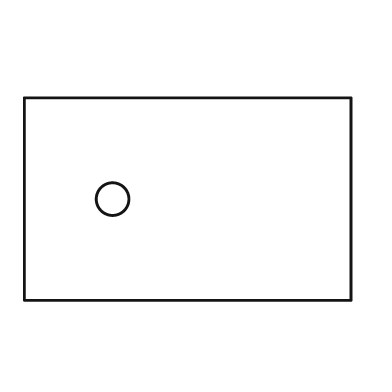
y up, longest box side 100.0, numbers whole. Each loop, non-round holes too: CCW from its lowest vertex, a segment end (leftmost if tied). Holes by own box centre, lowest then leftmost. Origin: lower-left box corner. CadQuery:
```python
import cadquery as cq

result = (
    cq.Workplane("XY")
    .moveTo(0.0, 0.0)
    .lineTo(100.0, 0.0)
    .lineTo(100.0, 62.0)
    .lineTo(0.0, 62.0)
    .close()
    .moveTo(27.0, 31.0)
    .circle(5.0)
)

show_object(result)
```